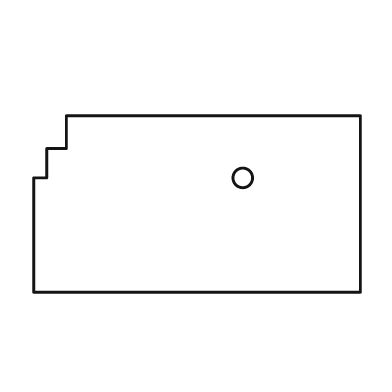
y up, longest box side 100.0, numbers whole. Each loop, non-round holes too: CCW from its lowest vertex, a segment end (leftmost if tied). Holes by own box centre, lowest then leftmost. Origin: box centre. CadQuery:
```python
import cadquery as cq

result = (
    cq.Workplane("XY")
    .moveTo(-50.0, -27.0)
    .lineTo(50.0, -27.0)
    .lineTo(50.0, 27.0)
    .lineTo(-40.0, 27.0)
    .lineTo(-40.0, 17.0)
    .lineTo(-46.0, 17.0)
    .lineTo(-46.0, 8.0)
    .lineTo(-50.0, 8.0)
    .close()
    .moveTo(14.0, 8.0)
    .circle(3.0)
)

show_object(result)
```